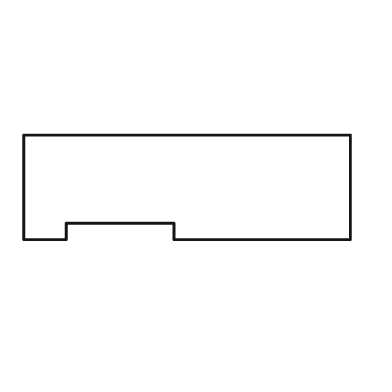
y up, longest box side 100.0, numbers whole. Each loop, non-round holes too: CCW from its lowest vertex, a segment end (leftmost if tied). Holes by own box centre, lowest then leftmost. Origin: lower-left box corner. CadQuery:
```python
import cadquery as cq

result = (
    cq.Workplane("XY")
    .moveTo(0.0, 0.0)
    .lineTo(13.0, 0.0)
    .lineTo(13.0, 5.0)
    .lineTo(46.0, 5.0)
    .lineTo(46.0, 0.0)
    .lineTo(100.0, 0.0)
    .lineTo(100.0, 32.0)
    .lineTo(0.0, 32.0)
    .close()
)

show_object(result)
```